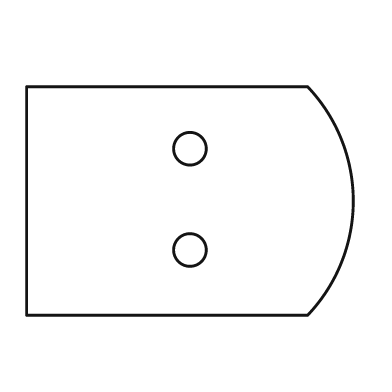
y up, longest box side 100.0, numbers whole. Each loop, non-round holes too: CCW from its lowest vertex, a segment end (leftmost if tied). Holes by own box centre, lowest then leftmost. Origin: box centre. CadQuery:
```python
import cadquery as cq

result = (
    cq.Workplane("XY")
    .moveTo(-50.0, -35.0)
    .lineTo(36.0, -35.0)
    .threePointArc((50.0, 0.0), (36.0, 35.0))
    .lineTo(-50.0, 35.0)
    .close()
    .moveTo(0.0, -15.0)
    .circle(5.0)
    .moveTo(0.0, 16.0)
    .circle(5.0)
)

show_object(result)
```